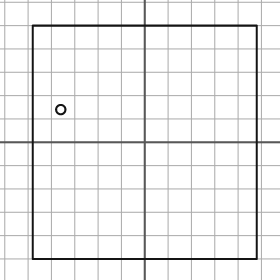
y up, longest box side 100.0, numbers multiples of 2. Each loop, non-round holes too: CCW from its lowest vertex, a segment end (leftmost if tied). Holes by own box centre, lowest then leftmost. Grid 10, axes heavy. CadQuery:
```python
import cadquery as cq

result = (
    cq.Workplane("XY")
    .moveTo(-48.0, -50.0)
    .lineTo(48.0, -50.0)
    .lineTo(48.0, 50.0)
    .lineTo(-48.0, 50.0)
    .close()
    .moveTo(-36.0, 14.0)
    .circle(2.0)
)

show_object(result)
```